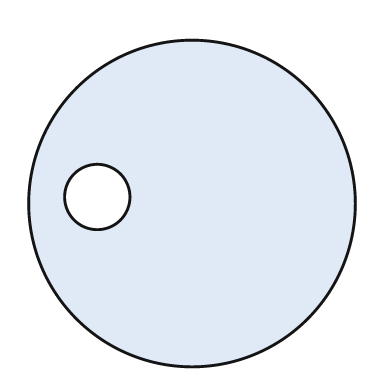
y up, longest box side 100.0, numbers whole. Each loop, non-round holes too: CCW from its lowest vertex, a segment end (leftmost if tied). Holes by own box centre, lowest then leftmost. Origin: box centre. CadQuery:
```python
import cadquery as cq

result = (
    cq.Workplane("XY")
    .moveTo(0.0, 0.0)
    .circle(50.0)
    .moveTo(-29.0, 2.0)
    .circle(10.0)
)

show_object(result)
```